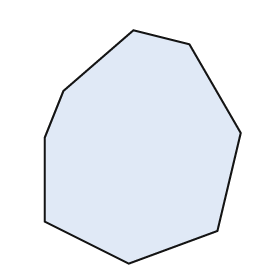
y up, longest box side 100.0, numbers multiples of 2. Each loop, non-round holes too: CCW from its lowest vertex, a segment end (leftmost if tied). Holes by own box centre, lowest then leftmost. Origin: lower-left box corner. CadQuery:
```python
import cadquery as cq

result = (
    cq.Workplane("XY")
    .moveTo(36.0, 0.0)
    .lineTo(74.0, 14.0)
    .lineTo(84.0, 56.0)
    .lineTo(62.0, 94.0)
    .lineTo(38.0, 100.0)
    .lineTo(8.0, 74.0)
    .lineTo(0.0, 54.0)
    .lineTo(0.0, 18.0)
    .close()
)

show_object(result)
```